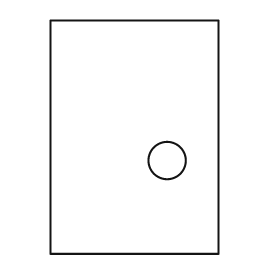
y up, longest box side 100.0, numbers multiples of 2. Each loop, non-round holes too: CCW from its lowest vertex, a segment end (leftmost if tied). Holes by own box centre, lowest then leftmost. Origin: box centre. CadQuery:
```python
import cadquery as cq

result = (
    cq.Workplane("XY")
    .moveTo(-36.0, -50.0)
    .lineTo(36.0, -50.0)
    .lineTo(36.0, 50.0)
    .lineTo(-36.0, 50.0)
    .close()
    .moveTo(14.0, -10.0)
    .circle(8.0)
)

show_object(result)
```